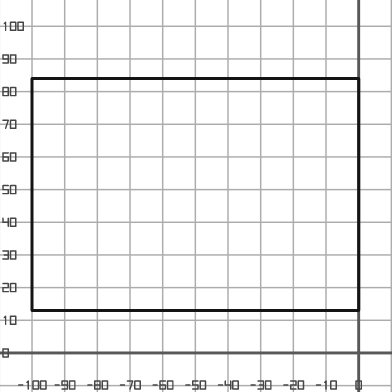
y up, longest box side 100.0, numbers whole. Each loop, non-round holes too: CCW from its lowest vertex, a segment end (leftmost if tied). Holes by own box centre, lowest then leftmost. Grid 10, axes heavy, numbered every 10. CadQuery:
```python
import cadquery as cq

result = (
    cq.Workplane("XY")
    .moveTo(-100.0, 13.0)
    .lineTo(0.0, 13.0)
    .lineTo(0.0, 84.0)
    .lineTo(-100.0, 84.0)
    .close()
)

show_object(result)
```